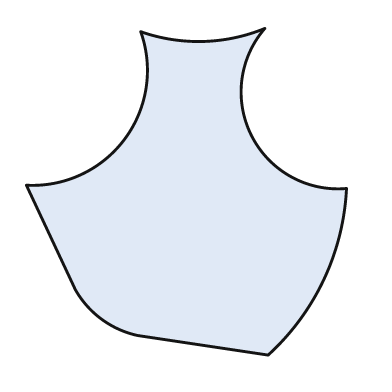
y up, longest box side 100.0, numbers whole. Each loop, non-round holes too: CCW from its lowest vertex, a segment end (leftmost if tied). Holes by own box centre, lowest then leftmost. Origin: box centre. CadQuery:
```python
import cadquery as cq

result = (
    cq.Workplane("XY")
    .moveTo(25.0, -50.0)
    .threePointArc((42.0, -27.0), (49.0, 1.0))
    .threePointArc((20.0, 17.0), (24.0, 50.0))
    .threePointArc((5.0, 46.0), (-14.0, 49.0))
    .threePointArc((-19.0, 16.0), (-49.0, 2.0))
    .lineTo(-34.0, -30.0)
    .threePointArc((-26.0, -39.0), (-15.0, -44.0))
    .close()
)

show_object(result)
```